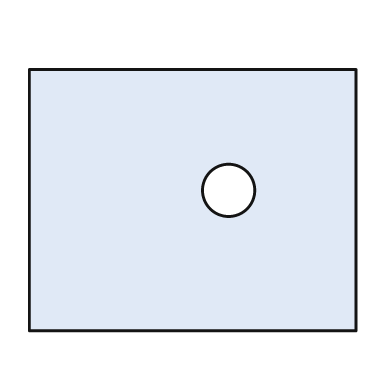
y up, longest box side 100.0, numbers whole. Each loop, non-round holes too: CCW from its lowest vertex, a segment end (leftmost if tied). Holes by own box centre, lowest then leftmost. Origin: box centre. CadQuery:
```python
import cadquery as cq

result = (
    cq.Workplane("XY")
    .moveTo(-50.0, -40.0)
    .lineTo(50.0, -40.0)
    .lineTo(50.0, 40.0)
    .lineTo(-50.0, 40.0)
    .close()
    .moveTo(11.0, 3.0)
    .circle(8.0)
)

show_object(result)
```